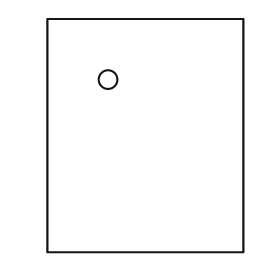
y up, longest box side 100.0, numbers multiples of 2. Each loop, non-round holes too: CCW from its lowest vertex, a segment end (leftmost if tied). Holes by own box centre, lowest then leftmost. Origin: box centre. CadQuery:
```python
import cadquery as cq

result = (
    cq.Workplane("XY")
    .moveTo(-42.0, -50.0)
    .lineTo(42.0, -50.0)
    .lineTo(42.0, 50.0)
    .lineTo(-42.0, 50.0)
    .close()
    .moveTo(-16.0, 24.0)
    .circle(4.0)
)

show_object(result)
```